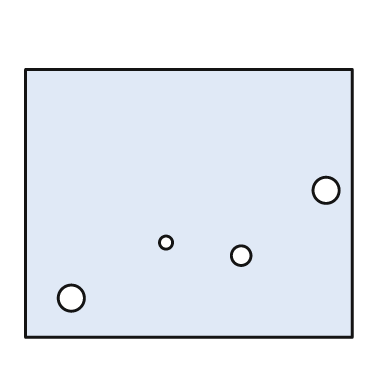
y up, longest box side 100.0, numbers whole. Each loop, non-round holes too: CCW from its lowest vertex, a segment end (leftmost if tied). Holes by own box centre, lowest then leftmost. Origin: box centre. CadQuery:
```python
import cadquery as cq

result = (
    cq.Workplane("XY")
    .moveTo(-50.0, -41.0)
    .lineTo(50.0, -41.0)
    .lineTo(50.0, 41.0)
    .lineTo(-50.0, 41.0)
    .close()
    .moveTo(-36.0, -29.0)
    .circle(4.0)
    .moveTo(16.0, -16.0)
    .circle(3.0)
    .moveTo(-7.0, -12.0)
    .circle(2.0)
    .moveTo(42.0, 4.0)
    .circle(4.0)
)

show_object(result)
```